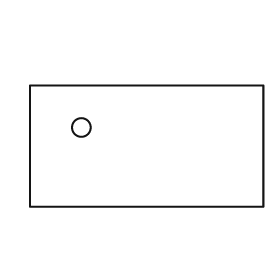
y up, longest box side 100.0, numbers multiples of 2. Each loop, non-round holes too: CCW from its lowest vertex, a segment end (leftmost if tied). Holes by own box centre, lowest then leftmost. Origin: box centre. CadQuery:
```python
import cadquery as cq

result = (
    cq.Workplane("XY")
    .moveTo(-50.0, -26.0)
    .lineTo(50.0, -26.0)
    .lineTo(50.0, 26.0)
    .lineTo(-50.0, 26.0)
    .close()
    .moveTo(-28.0, 8.0)
    .circle(4.0)
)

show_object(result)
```